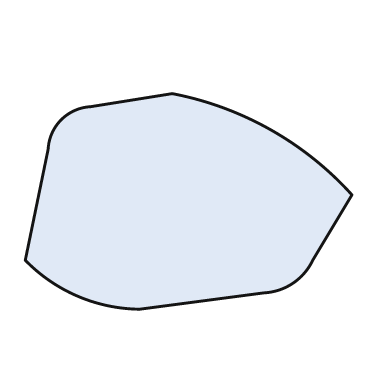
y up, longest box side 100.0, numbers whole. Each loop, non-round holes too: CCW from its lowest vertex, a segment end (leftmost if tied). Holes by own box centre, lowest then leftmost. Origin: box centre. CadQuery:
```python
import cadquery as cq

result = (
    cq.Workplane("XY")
    .moveTo(-15.0, -33.0)
    .lineTo(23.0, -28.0)
    .threePointArc((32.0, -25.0), (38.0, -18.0))
    .lineTo(50.0, 2.0)
    .threePointArc((25.0, 22.0), (-5.0, 33.0))
    .lineTo(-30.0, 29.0)
    .threePointArc((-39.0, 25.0), (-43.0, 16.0))
    .lineTo(-50.0, -18.0)
    .threePointArc((-34.0, -29.0), (-15.0, -33.0))
    .close()
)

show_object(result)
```